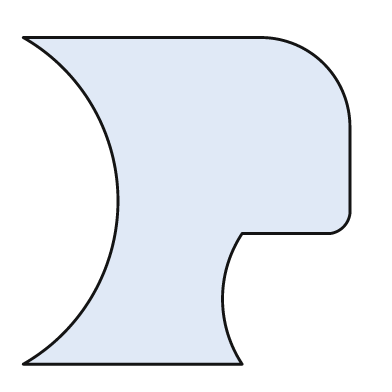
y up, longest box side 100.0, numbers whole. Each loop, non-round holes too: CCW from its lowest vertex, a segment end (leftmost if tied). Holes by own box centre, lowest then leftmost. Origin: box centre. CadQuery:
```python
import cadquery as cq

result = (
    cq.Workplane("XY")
    .moveTo(-50.0, -50.0)
    .lineTo(17.0, -50.0)
    .threePointArc((11.0, -30.0), (17.0, -10.0))
    .lineTo(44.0, -10.0)
    .threePointArc((48.0, -8.0), (50.0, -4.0))
    .lineTo(50.0, 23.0)
    .threePointArc((42.0, 42.0), (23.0, 50.0))
    .lineTo(-50.0, 50.0)
    .threePointArc((-21.0, 0.0), (-50.0, -50.0))
    .close()
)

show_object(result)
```